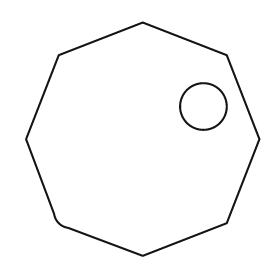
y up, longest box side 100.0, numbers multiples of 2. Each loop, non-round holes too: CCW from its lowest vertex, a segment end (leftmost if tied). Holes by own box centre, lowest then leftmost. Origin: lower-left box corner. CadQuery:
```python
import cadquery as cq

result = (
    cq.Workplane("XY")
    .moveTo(50.0, 0.0)
    .lineTo(86.0, 14.0)
    .lineTo(100.0, 50.0)
    .lineTo(86.0, 86.0)
    .lineTo(50.0, 100.0)
    .lineTo(14.0, 86.0)
    .lineTo(0.0, 50.0)
    .lineTo(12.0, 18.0)
    .threePointArc((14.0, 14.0), (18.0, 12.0))
    .close()
    .moveTo(76.0, 64.0)
    .circle(10.0)
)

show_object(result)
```